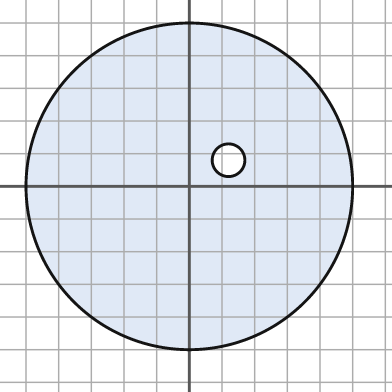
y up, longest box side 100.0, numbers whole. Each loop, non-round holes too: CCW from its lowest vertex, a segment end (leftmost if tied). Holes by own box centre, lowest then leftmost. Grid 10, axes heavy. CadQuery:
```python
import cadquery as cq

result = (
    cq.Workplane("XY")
    .moveTo(0.0, 0.0)
    .circle(50.0)
    .moveTo(12.0, 8.0)
    .circle(5.0)
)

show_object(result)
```